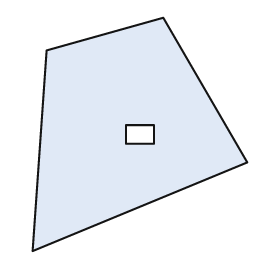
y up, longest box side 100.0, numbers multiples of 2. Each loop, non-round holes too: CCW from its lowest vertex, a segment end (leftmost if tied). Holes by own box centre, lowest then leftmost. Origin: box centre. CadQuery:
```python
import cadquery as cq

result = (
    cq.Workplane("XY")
    .moveTo(-46.0, -50.0)
    .lineTo(46.0, -12.0)
    .lineTo(10.0, 50.0)
    .lineTo(-40.0, 36.0)
    .close()
    .moveTo(-6.0, -4.0)
    .lineTo(6.0, -4.0)
    .lineTo(6.0, 4.0)
    .lineTo(-6.0, 4.0)
    .close()
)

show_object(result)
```